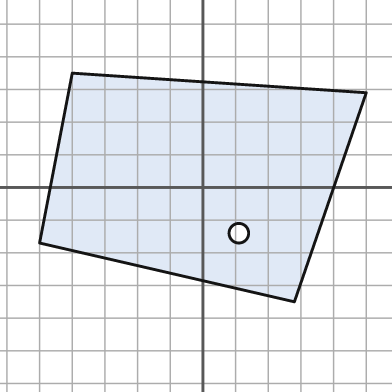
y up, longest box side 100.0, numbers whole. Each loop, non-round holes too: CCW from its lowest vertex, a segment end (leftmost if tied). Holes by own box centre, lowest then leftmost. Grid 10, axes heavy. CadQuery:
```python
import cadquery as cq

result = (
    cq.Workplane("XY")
    .moveTo(28.0, -35.0)
    .lineTo(50.0, 29.0)
    .lineTo(-40.0, 35.0)
    .lineTo(-50.0, -17.0)
    .close()
    .moveTo(11.0, -14.0)
    .circle(3.0)
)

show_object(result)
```